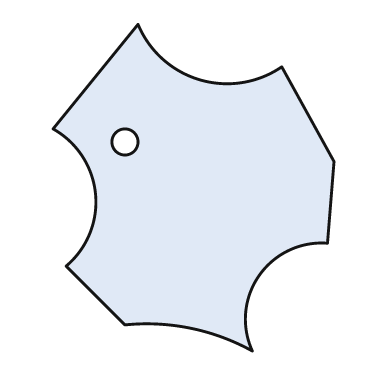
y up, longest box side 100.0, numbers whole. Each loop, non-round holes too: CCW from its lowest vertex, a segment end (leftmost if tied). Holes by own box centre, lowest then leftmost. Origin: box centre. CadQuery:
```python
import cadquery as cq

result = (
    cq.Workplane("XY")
    .moveTo(18.0, -50.0)
    .threePointArc((20.0, -27.0), (41.0, -17.0))
    .lineTo(43.0, 8.0)
    .lineTo(27.0, 37.0)
    .threePointArc((2.0, 33.0), (-17.0, 50.0))
    .lineTo(-43.0, 18.0)
    .threePointArc((-30.0, -2.0), (-39.0, -24.0))
    .lineTo(-21.0, -42.0)
    .threePointArc((-1.0, -43.0), (18.0, -50.0))
    .close()
    .moveTo(-21.0, 14.0)
    .circle(4.0)
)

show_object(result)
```